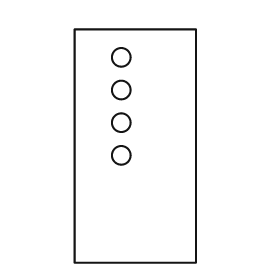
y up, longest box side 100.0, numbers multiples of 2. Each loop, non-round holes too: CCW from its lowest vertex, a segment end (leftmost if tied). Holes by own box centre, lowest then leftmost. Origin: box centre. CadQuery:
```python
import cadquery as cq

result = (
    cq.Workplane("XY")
    .moveTo(-26.0, -50.0)
    .lineTo(26.0, -50.0)
    .lineTo(26.0, 50.0)
    .lineTo(-26.0, 50.0)
    .close()
    .moveTo(-6.0, -4.0)
    .circle(4.0)
    .moveTo(-6.0, 10.0)
    .circle(4.0)
    .moveTo(-6.0, 24.0)
    .circle(4.0)
    .moveTo(-6.0, 38.0)
    .circle(4.0)
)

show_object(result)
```